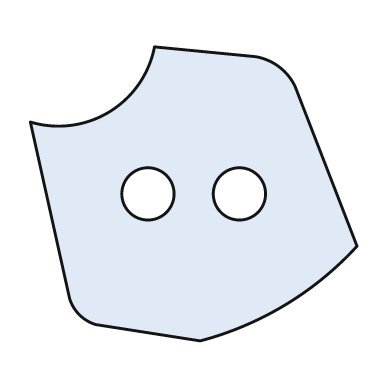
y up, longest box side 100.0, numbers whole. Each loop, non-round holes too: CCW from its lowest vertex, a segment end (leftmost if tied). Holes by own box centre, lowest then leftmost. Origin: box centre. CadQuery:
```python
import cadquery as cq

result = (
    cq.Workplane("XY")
    .moveTo(2.0, -45.0)
    .threePointArc((28.0, -34.0), (50.0, -16.0))
    .lineTo(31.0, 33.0)
    .threePointArc((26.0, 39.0), (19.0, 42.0))
    .lineTo(-12.0, 45.0)
    .threePointArc((-26.0, 25.0), (-50.0, 22.0))
    .lineTo(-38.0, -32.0)
    .threePointArc((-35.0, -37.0), (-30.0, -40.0))
    .close()
    .moveTo(-14.0, 0.0)
    .circle(8.0)
    .moveTo(14.0, 0.0)
    .circle(8.0)
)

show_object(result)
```